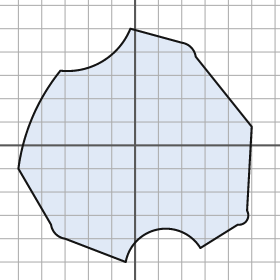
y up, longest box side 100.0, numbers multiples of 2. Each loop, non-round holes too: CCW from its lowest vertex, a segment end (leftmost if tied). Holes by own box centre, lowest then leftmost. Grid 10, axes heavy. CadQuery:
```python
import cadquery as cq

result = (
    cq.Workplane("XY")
    .moveTo(-4.0, -50.0)
    .threePointArc((10.0, -36.0), (28.0, -44.0))
    .lineTo(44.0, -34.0)
    .threePointArc((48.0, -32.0), (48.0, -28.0))
    .lineTo(50.0, 8.0)
    .lineTo(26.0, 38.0)
    .threePointArc((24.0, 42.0), (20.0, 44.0))
    .lineTo(-2.0, 50.0)
    .threePointArc((-14.0, 36.0), (-32.0, 32.0))
    .threePointArc((-44.0, 12.0), (-50.0, -10.0))
    .lineTo(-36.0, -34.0)
    .threePointArc((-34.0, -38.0), (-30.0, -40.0))
    .close()
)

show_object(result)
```